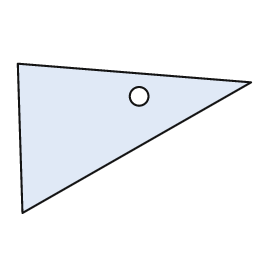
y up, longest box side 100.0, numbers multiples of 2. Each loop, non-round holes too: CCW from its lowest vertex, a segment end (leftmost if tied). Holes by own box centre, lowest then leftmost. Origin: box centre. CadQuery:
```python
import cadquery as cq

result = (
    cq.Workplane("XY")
    .moveTo(-48.0, -32.0)
    .lineTo(50.0, 24.0)
    .lineTo(-50.0, 32.0)
    .close()
    .moveTo(2.0, 18.0)
    .circle(4.0)
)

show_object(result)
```